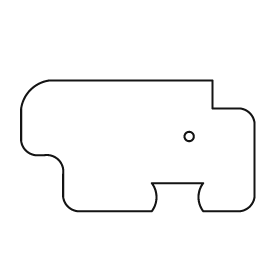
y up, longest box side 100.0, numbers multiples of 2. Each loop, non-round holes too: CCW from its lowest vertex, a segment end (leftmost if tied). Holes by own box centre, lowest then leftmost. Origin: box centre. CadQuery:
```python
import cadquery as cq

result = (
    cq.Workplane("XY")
    .moveTo(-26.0, -28.0)
    .lineTo(6.0, -28.0)
    .threePointArc((8.0, -22.0), (6.0, -16.0))
    .lineTo(28.0, -16.0)
    .threePointArc((26.0, -22.0), (28.0, -28.0))
    .lineTo(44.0, -28.0)
    .threePointArc((48.0, -26.0), (50.0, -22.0))
    .lineTo(50.0, 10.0)
    .threePointArc((48.0, 14.0), (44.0, 16.0))
    .lineTo(32.0, 16.0)
    .lineTo(32.0, 28.0)
    .lineTo(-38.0, 28.0)
    .threePointArc((-46.0, 24.0), (-50.0, 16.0))
    .lineTo(-50.0, 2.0)
    .threePointArc((-48.0, -2.0), (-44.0, -4.0))
    .lineTo(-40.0, -4.0)
    .threePointArc((-34.0, -6.0), (-32.0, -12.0))
    .lineTo(-32.0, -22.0)
    .threePointArc((-30.0, -26.0), (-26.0, -28.0))
    .close()
    .moveTo(22.0, 4.0)
    .circle(2.0)
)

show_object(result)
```